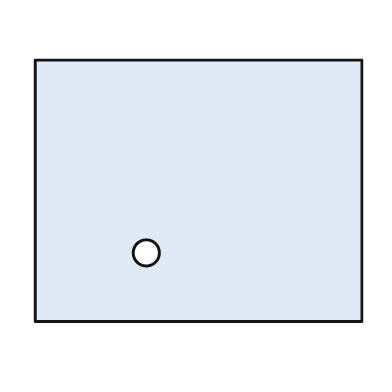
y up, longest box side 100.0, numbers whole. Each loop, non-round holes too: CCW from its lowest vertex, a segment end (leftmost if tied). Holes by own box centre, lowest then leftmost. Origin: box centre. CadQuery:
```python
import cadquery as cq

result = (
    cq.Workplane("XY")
    .moveTo(-50.0, -40.0)
    .lineTo(50.0, -40.0)
    .lineTo(50.0, 40.0)
    .lineTo(-50.0, 40.0)
    .close()
    .moveTo(-16.0, -19.0)
    .circle(4.0)
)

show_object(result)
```